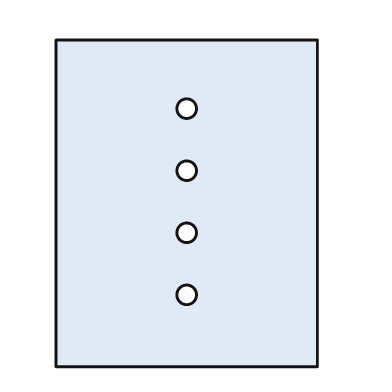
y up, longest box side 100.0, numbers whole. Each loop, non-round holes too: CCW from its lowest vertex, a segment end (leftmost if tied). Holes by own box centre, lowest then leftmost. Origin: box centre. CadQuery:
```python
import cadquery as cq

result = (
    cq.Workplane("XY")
    .moveTo(-40.0, -50.0)
    .lineTo(40.0, -50.0)
    .lineTo(40.0, 50.0)
    .lineTo(-40.0, 50.0)
    .close()
    .moveTo(0.0, -28.0)
    .circle(3.0)
    .moveTo(0.0, -9.0)
    .circle(3.0)
    .moveTo(0.0, 10.0)
    .circle(3.0)
    .moveTo(0.0, 29.0)
    .circle(3.0)
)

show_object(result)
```